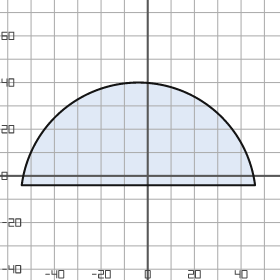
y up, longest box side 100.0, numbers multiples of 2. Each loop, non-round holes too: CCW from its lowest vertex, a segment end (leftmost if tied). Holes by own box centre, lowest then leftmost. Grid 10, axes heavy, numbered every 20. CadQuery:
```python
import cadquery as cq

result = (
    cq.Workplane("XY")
    .moveTo(-54.0, -4.0)
    .lineTo(46.0, -4.0)
    .threePointArc((-4.0, 40.0), (-54.0, -4.0))
    .close()
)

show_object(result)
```